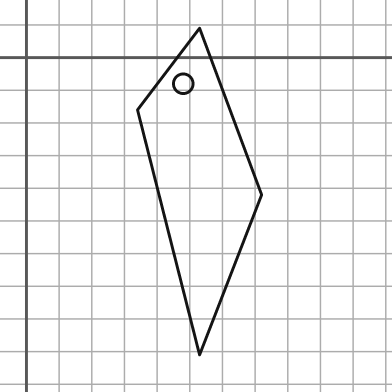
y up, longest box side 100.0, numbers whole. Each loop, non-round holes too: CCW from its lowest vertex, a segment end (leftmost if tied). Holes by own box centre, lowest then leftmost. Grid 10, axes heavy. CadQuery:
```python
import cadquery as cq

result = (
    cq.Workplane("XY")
    .moveTo(53.0, -91.0)
    .lineTo(72.0, -42.0)
    .lineTo(53.0, 9.0)
    .lineTo(34.0, -16.0)
    .close()
    .moveTo(48.0, -8.0)
    .circle(3.0)
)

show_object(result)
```